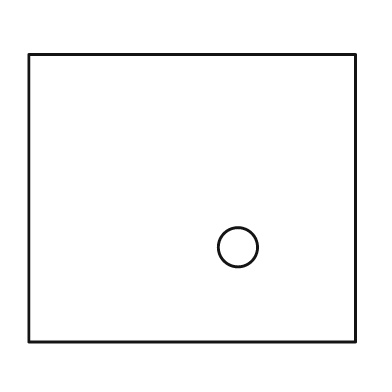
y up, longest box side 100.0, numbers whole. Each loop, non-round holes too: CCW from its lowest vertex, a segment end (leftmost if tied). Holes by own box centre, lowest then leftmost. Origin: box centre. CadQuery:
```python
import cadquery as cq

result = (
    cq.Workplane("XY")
    .moveTo(-50.0, -44.0)
    .lineTo(50.0, -44.0)
    .lineTo(50.0, 44.0)
    .lineTo(-50.0, 44.0)
    .close()
    .moveTo(14.0, -15.0)
    .circle(6.0)
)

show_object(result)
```